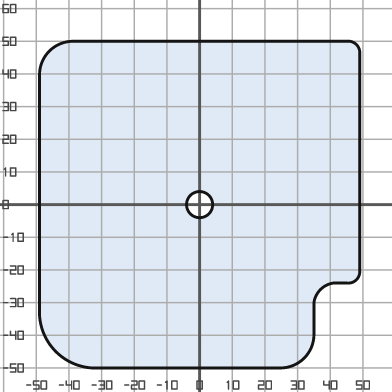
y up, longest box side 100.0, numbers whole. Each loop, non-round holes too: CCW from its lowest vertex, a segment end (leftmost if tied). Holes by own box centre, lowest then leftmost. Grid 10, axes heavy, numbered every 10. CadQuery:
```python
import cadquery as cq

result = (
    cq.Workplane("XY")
    .moveTo(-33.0, -50.0)
    .lineTo(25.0, -50.0)
    .threePointArc((32.0, -47.0), (35.0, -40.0))
    .lineTo(35.0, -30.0)
    .threePointArc((37.0, -26.0), (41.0, -24.0))
    .lineTo(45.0, -24.0)
    .threePointArc((48.0, -23.0), (49.0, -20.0))
    .lineTo(49.0, 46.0)
    .threePointArc((48.0, 49.0), (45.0, 50.0))
    .lineTo(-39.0, 50.0)
    .threePointArc((-46.0, 47.0), (-49.0, 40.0))
    .lineTo(-49.0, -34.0)
    .threePointArc((-44.0, -45.0), (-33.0, -50.0))
    .close()
    .moveTo(0.0, 0.0)
    .circle(4.0)
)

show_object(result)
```